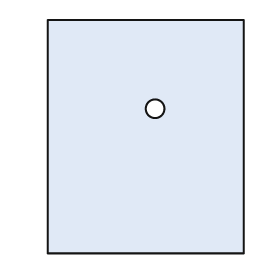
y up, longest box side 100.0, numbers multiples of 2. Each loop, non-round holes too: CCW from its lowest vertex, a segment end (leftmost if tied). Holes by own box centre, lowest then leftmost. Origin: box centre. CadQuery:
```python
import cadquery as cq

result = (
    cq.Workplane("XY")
    .moveTo(-42.0, -50.0)
    .lineTo(42.0, -50.0)
    .lineTo(42.0, 50.0)
    .lineTo(-42.0, 50.0)
    .close()
    .moveTo(4.0, 12.0)
    .circle(4.0)
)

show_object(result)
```